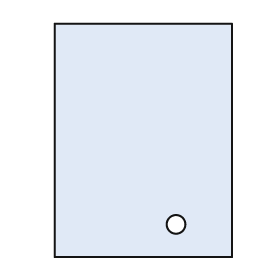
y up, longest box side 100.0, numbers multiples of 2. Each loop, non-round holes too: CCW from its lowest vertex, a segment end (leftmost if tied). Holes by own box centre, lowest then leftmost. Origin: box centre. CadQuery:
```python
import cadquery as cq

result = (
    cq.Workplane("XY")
    .moveTo(-38.0, -50.0)
    .lineTo(38.0, -50.0)
    .lineTo(38.0, 50.0)
    .lineTo(-38.0, 50.0)
    .close()
    .moveTo(14.0, -36.0)
    .circle(4.0)
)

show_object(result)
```